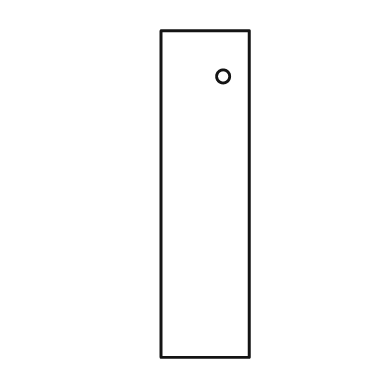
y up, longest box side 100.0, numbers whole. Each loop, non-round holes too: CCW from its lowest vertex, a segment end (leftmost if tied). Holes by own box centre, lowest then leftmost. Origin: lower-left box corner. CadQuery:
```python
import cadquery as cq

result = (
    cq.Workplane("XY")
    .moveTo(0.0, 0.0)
    .lineTo(27.0, 0.0)
    .lineTo(27.0, 100.0)
    .lineTo(0.0, 100.0)
    .close()
    .moveTo(19.0, 86.0)
    .circle(2.0)
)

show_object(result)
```